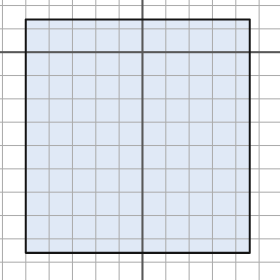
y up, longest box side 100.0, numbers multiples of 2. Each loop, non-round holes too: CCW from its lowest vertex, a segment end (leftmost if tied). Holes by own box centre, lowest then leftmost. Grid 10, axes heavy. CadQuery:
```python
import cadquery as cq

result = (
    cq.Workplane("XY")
    .moveTo(-50.0, -86.0)
    .lineTo(46.0, -86.0)
    .lineTo(46.0, 14.0)
    .lineTo(-50.0, 14.0)
    .close()
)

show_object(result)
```